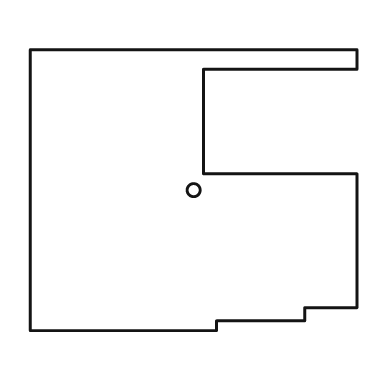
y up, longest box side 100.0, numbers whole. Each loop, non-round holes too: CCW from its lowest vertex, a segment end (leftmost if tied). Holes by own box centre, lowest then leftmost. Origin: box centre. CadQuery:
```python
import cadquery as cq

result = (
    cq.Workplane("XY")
    .moveTo(-50.0, -43.0)
    .lineTo(7.0, -43.0)
    .lineTo(7.0, -40.0)
    .lineTo(34.0, -40.0)
    .lineTo(34.0, -36.0)
    .lineTo(50.0, -36.0)
    .lineTo(50.0, 5.0)
    .lineTo(3.0, 5.0)
    .lineTo(3.0, 37.0)
    .lineTo(50.0, 37.0)
    .lineTo(50.0, 43.0)
    .lineTo(-50.0, 43.0)
    .close()
    .moveTo(0.0, 0.0)
    .circle(2.0)
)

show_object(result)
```